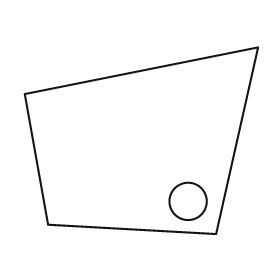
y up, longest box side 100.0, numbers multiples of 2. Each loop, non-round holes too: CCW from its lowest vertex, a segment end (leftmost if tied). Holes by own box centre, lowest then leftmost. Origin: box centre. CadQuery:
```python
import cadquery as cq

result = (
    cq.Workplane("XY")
    .moveTo(32.0, -40.0)
    .lineTo(50.0, 40.0)
    .lineTo(-50.0, 20.0)
    .lineTo(-40.0, -36.0)
    .close()
    .moveTo(20.0, -26.0)
    .circle(8.0)
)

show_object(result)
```